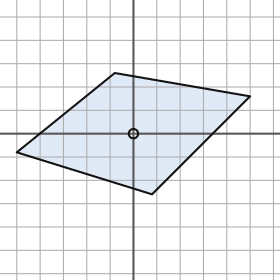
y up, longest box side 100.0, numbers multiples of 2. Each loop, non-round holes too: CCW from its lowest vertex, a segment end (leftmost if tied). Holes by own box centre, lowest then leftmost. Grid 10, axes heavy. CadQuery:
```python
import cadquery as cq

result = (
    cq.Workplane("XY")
    .moveTo(8.0, -26.0)
    .lineTo(50.0, 16.0)
    .lineTo(-8.0, 26.0)
    .lineTo(-50.0, -8.0)
    .close()
    .moveTo(0.0, 0.0)
    .circle(2.0)
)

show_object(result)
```